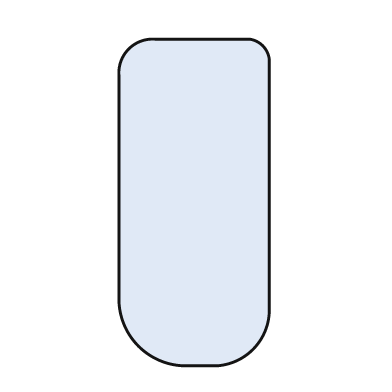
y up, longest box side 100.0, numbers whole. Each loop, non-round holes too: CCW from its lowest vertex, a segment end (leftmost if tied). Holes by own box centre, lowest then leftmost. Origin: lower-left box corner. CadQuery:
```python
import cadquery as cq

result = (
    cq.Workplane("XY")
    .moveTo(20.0, 0.0)
    .lineTo(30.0, 0.0)
    .threePointArc((41.0, 5.0), (46.0, 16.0))
    .lineTo(46.0, 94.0)
    .threePointArc((44.0, 98.0), (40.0, 100.0))
    .lineTo(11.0, 100.0)
    .threePointArc((3.0, 97.0), (0.0, 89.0))
    .lineTo(0.0, 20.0)
    .threePointArc((6.0, 6.0), (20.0, 0.0))
    .close()
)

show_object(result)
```